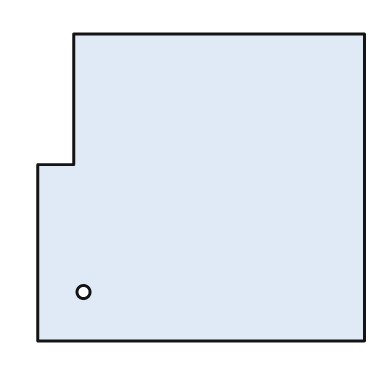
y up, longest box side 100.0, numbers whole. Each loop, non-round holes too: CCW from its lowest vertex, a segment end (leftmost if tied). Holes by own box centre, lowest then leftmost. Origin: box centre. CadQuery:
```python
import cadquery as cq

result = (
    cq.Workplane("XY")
    .moveTo(-50.0, -47.0)
    .lineTo(50.0, -47.0)
    .lineTo(50.0, 47.0)
    .lineTo(-39.0, 47.0)
    .lineTo(-39.0, 7.0)
    .lineTo(-50.0, 7.0)
    .close()
    .moveTo(-36.0, -32.0)
    .circle(2.0)
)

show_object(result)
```